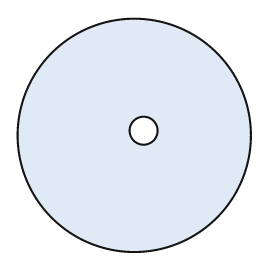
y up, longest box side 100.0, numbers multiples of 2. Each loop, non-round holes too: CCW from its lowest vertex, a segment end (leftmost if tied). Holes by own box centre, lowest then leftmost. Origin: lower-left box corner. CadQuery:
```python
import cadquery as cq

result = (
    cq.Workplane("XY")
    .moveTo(50.0, 50.0)
    .circle(50.0)
    .moveTo(54.0, 52.0)
    .circle(6.0)
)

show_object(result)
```